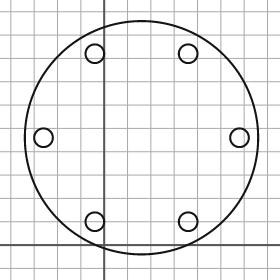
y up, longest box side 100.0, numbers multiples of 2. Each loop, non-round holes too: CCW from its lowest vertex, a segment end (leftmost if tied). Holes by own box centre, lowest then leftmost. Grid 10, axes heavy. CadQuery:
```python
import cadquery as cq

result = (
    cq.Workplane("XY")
    .moveTo(16.0, 46.0)
    .circle(50.0)
    .moveTo(-4.0, 10.0)
    .circle(4.0)
    .moveTo(36.0, 10.0)
    .circle(4.0)
    .moveTo(-26.0, 46.0)
    .circle(4.0)
    .moveTo(58.0, 46.0)
    .circle(4.0)
    .moveTo(-4.0, 82.0)
    .circle(4.0)
    .moveTo(36.0, 82.0)
    .circle(4.0)
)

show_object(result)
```